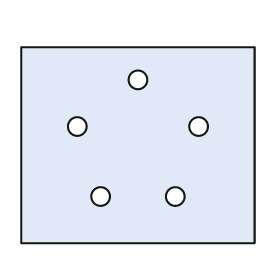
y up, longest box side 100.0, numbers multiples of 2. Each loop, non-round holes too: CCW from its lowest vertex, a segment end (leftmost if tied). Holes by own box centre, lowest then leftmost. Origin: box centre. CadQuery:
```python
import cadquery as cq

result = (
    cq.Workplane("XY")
    .moveTo(-50.0, -42.0)
    .lineTo(50.0, -42.0)
    .lineTo(50.0, 42.0)
    .lineTo(-50.0, 42.0)
    .close()
    .moveTo(-16.0, -22.0)
    .circle(4.0)
    .moveTo(16.0, -22.0)
    .circle(4.0)
    .moveTo(-26.0, 8.0)
    .circle(4.0)
    .moveTo(26.0, 8.0)
    .circle(4.0)
    .moveTo(0.0, 28.0)
    .circle(4.0)
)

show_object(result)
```